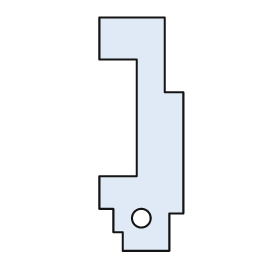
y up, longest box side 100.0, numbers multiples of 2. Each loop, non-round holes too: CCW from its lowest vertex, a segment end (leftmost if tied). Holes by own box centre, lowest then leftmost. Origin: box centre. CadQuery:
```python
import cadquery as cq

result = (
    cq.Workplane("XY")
    .moveTo(-8.0, -50.0)
    .lineTo(12.0, -50.0)
    .lineTo(12.0, -34.0)
    .lineTo(18.0, -34.0)
    .lineTo(18.0, 18.0)
    .lineTo(10.0, 18.0)
    .lineTo(10.0, 50.0)
    .lineTo(-18.0, 50.0)
    .lineTo(-18.0, 32.0)
    .lineTo(-2.0, 32.0)
    .lineTo(-2.0, -18.0)
    .lineTo(-18.0, -18.0)
    .lineTo(-18.0, -32.0)
    .lineTo(-12.0, -32.0)
    .lineTo(-12.0, -42.0)
    .lineTo(-8.0, -42.0)
    .close()
    .moveTo(0.0, -36.0)
    .circle(4.0)
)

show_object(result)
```